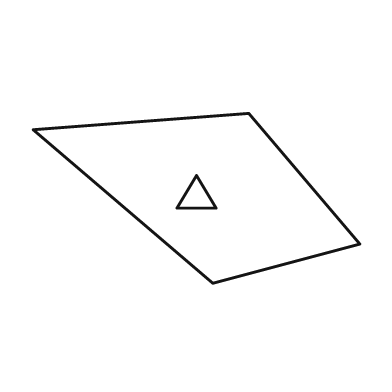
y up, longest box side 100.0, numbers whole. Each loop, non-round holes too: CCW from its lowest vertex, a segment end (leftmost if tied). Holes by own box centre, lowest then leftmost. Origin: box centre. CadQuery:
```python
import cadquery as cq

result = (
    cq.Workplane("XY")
    .moveTo(5.0, -26.0)
    .lineTo(50.0, -14.0)
    .lineTo(16.0, 26.0)
    .lineTo(-50.0, 21.0)
    .close()
    .moveTo(-6.0, -3.0)
    .lineTo(6.0, -3.0)
    .lineTo(0.0, 7.0)
    .close()
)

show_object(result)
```